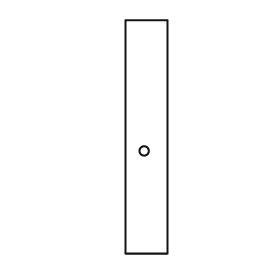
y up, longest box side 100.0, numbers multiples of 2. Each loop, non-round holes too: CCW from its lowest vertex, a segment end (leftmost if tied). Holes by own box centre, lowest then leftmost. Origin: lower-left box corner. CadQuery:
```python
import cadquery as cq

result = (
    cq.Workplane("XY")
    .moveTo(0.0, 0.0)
    .lineTo(18.0, 0.0)
    .lineTo(18.0, 100.0)
    .lineTo(0.0, 100.0)
    .close()
    .moveTo(8.0, 44.0)
    .circle(2.0)
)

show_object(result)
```